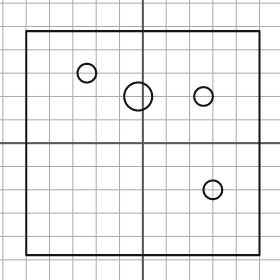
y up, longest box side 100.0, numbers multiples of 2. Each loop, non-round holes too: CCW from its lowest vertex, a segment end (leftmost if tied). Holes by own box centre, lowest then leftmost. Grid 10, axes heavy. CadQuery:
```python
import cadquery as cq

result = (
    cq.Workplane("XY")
    .moveTo(-50.0, -48.0)
    .lineTo(50.0, -48.0)
    .lineTo(50.0, 48.0)
    .lineTo(-50.0, 48.0)
    .close()
    .moveTo(30.0, -20.0)
    .circle(4.0)
    .moveTo(-2.0, 20.0)
    .circle(6.0)
    .moveTo(26.0, 20.0)
    .circle(4.0)
    .moveTo(-24.0, 30.0)
    .circle(4.0)
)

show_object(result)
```